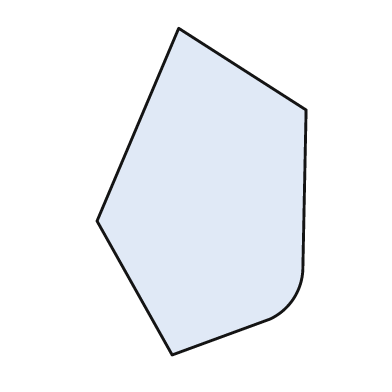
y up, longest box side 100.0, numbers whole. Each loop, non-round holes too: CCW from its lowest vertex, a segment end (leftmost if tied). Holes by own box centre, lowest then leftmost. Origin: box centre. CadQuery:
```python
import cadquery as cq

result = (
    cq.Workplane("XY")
    .moveTo(-9.0, -50.0)
    .lineTo(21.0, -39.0)
    .threePointArc((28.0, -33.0), (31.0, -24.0))
    .lineTo(32.0, 25.0)
    .lineTo(-7.0, 50.0)
    .lineTo(-32.0, -9.0)
    .close()
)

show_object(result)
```